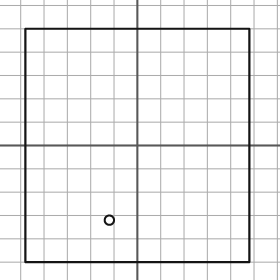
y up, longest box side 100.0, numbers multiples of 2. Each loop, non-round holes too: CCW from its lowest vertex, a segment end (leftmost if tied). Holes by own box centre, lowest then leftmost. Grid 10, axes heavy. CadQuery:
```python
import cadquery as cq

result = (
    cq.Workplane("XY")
    .moveTo(-48.0, -50.0)
    .lineTo(48.0, -50.0)
    .lineTo(48.0, 50.0)
    .lineTo(-48.0, 50.0)
    .close()
    .moveTo(-12.0, -32.0)
    .circle(2.0)
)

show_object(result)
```